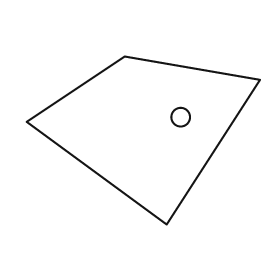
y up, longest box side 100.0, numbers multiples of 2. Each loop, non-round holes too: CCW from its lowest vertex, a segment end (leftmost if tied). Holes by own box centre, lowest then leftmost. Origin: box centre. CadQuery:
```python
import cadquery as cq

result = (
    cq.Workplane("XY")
    .moveTo(10.0, -36.0)
    .lineTo(50.0, 26.0)
    .lineTo(-8.0, 36.0)
    .lineTo(-50.0, 8.0)
    .close()
    .moveTo(16.0, 10.0)
    .circle(4.0)
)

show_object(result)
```